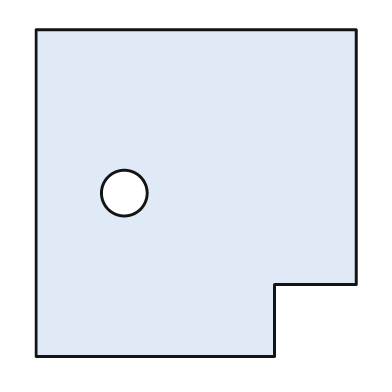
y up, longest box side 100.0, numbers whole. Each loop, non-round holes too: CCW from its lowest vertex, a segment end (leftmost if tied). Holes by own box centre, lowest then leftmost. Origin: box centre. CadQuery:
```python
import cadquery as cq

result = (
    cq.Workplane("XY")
    .moveTo(-49.0, -50.0)
    .lineTo(24.0, -50.0)
    .lineTo(24.0, -28.0)
    .lineTo(49.0, -28.0)
    .lineTo(49.0, 50.0)
    .lineTo(-49.0, 50.0)
    .close()
    .moveTo(-22.0, 0.0)
    .circle(7.0)
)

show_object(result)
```